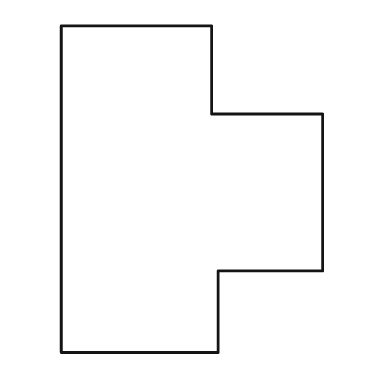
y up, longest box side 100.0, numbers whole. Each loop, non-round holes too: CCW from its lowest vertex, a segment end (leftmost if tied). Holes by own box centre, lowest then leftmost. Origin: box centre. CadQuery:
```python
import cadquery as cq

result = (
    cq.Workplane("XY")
    .moveTo(-40.0, -50.0)
    .lineTo(8.0, -50.0)
    .lineTo(8.0, -25.0)
    .lineTo(40.0, -25.0)
    .lineTo(40.0, 23.0)
    .lineTo(6.0, 23.0)
    .lineTo(6.0, 50.0)
    .lineTo(-40.0, 50.0)
    .close()
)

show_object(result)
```